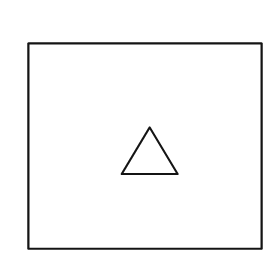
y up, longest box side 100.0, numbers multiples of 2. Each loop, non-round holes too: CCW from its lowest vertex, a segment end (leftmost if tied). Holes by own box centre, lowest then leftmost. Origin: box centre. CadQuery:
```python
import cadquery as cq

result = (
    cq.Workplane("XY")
    .moveTo(-50.0, -44.0)
    .lineTo(50.0, -44.0)
    .lineTo(50.0, 44.0)
    .lineTo(-50.0, 44.0)
    .close()
    .moveTo(-10.0, -12.0)
    .lineTo(14.0, -12.0)
    .lineTo(2.0, 8.0)
    .close()
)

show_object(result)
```